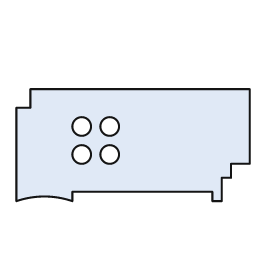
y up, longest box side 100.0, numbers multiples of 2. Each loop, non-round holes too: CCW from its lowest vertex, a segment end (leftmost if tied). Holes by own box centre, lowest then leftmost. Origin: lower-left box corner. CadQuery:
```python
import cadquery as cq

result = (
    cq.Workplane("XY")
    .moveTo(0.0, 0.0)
    .threePointArc((12.0, 2.0), (24.0, 0.0))
    .lineTo(24.0, 4.0)
    .lineTo(84.0, 4.0)
    .lineTo(84.0, 0.0)
    .lineTo(88.0, 0.0)
    .lineTo(88.0, 10.0)
    .lineTo(92.0, 10.0)
    .lineTo(92.0, 16.0)
    .lineTo(100.0, 16.0)
    .lineTo(100.0, 48.0)
    .lineTo(6.0, 48.0)
    .lineTo(6.0, 40.0)
    .lineTo(0.0, 40.0)
    .close()
    .moveTo(28.0, 20.0)
    .circle(4.0)
    .moveTo(40.0, 20.0)
    .circle(4.0)
    .moveTo(28.0, 32.0)
    .circle(4.0)
    .moveTo(40.0, 32.0)
    .circle(4.0)
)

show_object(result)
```